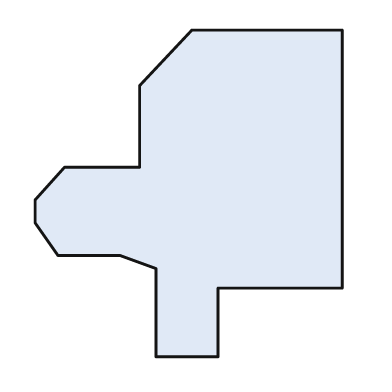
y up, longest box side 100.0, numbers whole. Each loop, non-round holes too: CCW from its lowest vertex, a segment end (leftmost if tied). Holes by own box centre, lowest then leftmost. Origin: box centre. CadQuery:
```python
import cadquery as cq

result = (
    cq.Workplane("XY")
    .moveTo(-10.0, -50.0)
    .lineTo(9.0, -50.0)
    .lineTo(9.0, -29.0)
    .lineTo(47.0, -29.0)
    .lineTo(47.0, 50.0)
    .lineTo(1.0, 50.0)
    .lineTo(-15.0, 33.0)
    .lineTo(-15.0, 8.0)
    .lineTo(-38.0, 8.0)
    .lineTo(-47.0, -2.0)
    .lineTo(-47.0, -9.0)
    .lineTo(-40.0, -19.0)
    .lineTo(-21.0, -19.0)
    .lineTo(-10.0, -23.0)
    .close()
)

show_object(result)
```